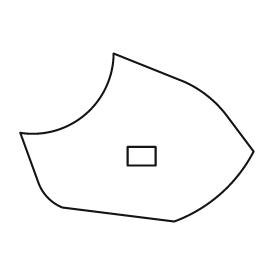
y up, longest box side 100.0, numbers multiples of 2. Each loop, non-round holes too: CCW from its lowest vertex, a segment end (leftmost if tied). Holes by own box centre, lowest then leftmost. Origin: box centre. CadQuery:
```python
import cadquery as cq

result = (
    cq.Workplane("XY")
    .moveTo(16.0, -36.0)
    .threePointArc((36.0, -24.0), (50.0, -6.0))
    .lineTo(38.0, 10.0)
    .threePointArc((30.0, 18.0), (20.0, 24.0))
    .lineTo(-10.0, 36.0)
    .threePointArc((-22.0, 10.0), (-50.0, 2.0))
    .lineTo(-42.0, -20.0)
    .threePointArc((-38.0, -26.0), (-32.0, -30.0))
    .close()
    .moveTo(-4.0, -12.0)
    .lineTo(8.0, -12.0)
    .lineTo(8.0, -4.0)
    .lineTo(-4.0, -4.0)
    .close()
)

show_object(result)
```